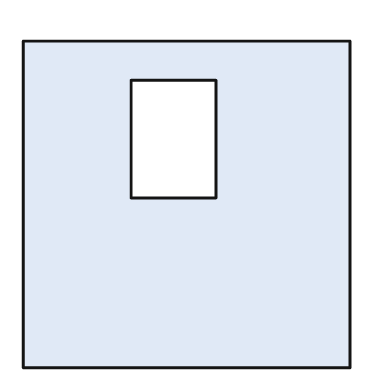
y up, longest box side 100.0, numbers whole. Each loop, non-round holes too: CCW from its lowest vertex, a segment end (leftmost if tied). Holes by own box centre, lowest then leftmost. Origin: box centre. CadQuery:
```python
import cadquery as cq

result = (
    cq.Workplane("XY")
    .moveTo(-50.0, -50.0)
    .lineTo(50.0, -50.0)
    .lineTo(50.0, 50.0)
    .lineTo(-50.0, 50.0)
    .close()
    .moveTo(-17.0, 2.0)
    .lineTo(9.0, 2.0)
    .lineTo(9.0, 38.0)
    .lineTo(-17.0, 38.0)
    .close()
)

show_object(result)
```